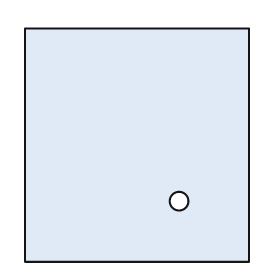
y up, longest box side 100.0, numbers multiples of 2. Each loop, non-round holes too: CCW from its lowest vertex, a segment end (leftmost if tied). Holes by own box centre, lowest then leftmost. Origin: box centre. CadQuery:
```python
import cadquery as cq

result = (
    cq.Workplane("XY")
    .moveTo(-48.0, -50.0)
    .lineTo(48.0, -50.0)
    .lineTo(48.0, 50.0)
    .lineTo(-48.0, 50.0)
    .close()
    .moveTo(18.0, -24.0)
    .circle(4.0)
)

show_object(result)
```